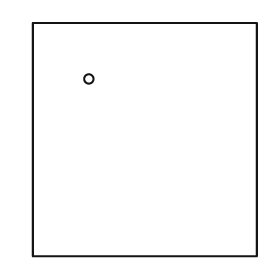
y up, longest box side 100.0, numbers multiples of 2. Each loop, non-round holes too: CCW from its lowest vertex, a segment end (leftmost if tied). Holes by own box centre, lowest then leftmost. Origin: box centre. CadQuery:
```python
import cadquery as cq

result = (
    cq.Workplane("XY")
    .moveTo(-48.0, -50.0)
    .lineTo(48.0, -50.0)
    .lineTo(48.0, 50.0)
    .lineTo(-48.0, 50.0)
    .close()
    .moveTo(-24.0, 26.0)
    .circle(2.0)
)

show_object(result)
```